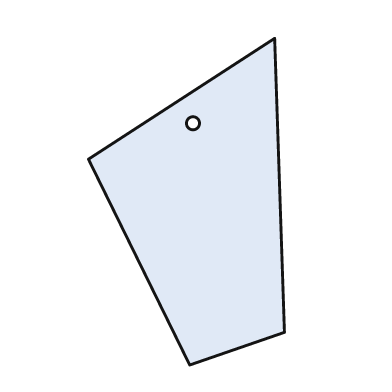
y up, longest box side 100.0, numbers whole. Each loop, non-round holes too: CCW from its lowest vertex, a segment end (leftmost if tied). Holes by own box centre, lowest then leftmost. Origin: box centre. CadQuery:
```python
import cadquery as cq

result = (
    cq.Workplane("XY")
    .moveTo(1.0, -50.0)
    .lineTo(30.0, -40.0)
    .lineTo(27.0, 50.0)
    .lineTo(-30.0, 13.0)
    .close()
    .moveTo(2.0, 24.0)
    .circle(2.0)
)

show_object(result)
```